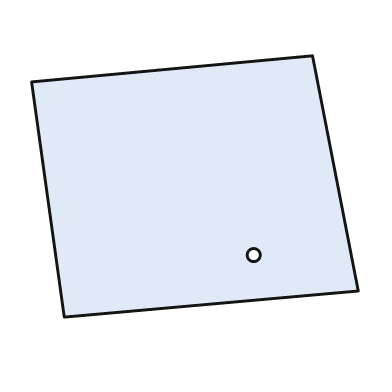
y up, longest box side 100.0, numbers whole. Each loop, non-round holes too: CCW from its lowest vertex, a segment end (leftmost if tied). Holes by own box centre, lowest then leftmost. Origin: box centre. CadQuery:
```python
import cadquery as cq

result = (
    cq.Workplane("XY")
    .moveTo(-40.0, -40.0)
    .lineTo(50.0, -32.0)
    .lineTo(36.0, 40.0)
    .lineTo(-50.0, 32.0)
    .close()
    .moveTo(18.0, -21.0)
    .circle(2.0)
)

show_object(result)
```